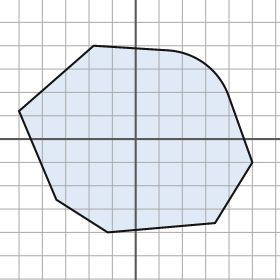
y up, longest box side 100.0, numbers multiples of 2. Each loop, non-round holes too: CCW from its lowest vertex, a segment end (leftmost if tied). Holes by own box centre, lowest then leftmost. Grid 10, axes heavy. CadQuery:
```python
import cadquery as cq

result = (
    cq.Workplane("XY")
    .moveTo(-12.0, -40.0)
    .lineTo(34.0, -36.0)
    .lineTo(50.0, -10.0)
    .lineTo(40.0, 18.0)
    .threePointArc((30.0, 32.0), (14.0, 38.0))
    .lineTo(-18.0, 40.0)
    .lineTo(-50.0, 12.0)
    .lineTo(-34.0, -26.0)
    .close()
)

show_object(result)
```